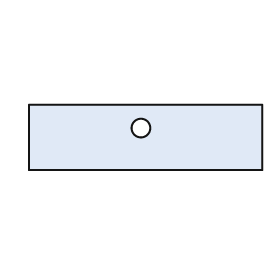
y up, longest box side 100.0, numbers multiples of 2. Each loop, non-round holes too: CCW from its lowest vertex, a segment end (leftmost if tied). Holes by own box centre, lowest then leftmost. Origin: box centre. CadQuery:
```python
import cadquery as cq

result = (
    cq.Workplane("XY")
    .moveTo(-50.0, -14.0)
    .lineTo(50.0, -14.0)
    .lineTo(50.0, 14.0)
    .lineTo(-50.0, 14.0)
    .close()
    .moveTo(-2.0, 4.0)
    .circle(4.0)
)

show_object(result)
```